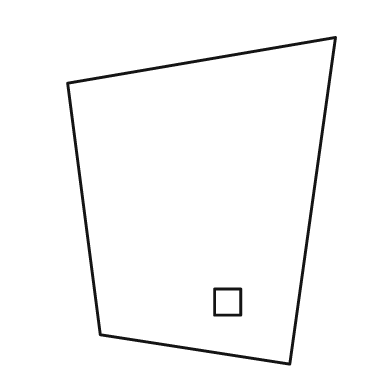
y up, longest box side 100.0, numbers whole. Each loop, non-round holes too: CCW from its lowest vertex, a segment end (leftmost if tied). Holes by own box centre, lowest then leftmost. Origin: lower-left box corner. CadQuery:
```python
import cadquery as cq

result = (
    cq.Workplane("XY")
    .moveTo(68.0, 0.0)
    .lineTo(82.0, 100.0)
    .lineTo(0.0, 86.0)
    .lineTo(10.0, 9.0)
    .close()
    .moveTo(45.0, 15.0)
    .lineTo(53.0, 15.0)
    .lineTo(53.0, 23.0)
    .lineTo(45.0, 23.0)
    .close()
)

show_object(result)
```